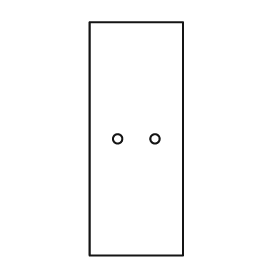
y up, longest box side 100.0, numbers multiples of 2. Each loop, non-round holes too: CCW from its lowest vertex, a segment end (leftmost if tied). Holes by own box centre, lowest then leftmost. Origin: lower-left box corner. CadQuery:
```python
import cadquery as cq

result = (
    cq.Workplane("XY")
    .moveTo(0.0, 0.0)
    .lineTo(40.0, 0.0)
    .lineTo(40.0, 100.0)
    .lineTo(0.0, 100.0)
    .close()
    .moveTo(12.0, 50.0)
    .circle(2.0)
    .moveTo(28.0, 50.0)
    .circle(2.0)
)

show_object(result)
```